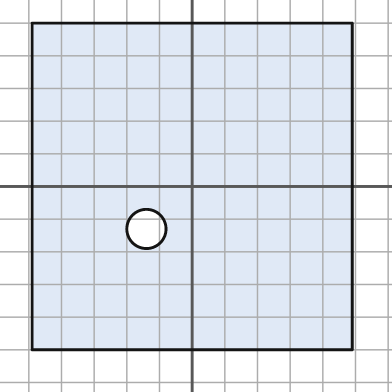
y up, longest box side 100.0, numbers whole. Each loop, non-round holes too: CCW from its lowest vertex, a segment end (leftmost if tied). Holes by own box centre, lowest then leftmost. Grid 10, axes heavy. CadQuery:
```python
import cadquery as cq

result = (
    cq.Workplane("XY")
    .moveTo(-49.0, -50.0)
    .lineTo(49.0, -50.0)
    .lineTo(49.0, 50.0)
    .lineTo(-49.0, 50.0)
    .close()
    .moveTo(-14.0, -13.0)
    .circle(6.0)
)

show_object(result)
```